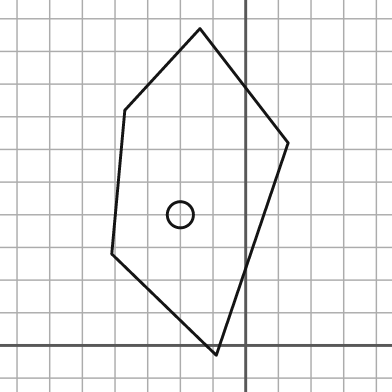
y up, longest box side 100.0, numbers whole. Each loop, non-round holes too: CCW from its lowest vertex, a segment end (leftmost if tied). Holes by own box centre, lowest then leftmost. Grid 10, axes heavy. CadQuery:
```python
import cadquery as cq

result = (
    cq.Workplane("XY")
    .moveTo(-9.0, -3.0)
    .lineTo(13.0, 62.0)
    .lineTo(-14.0, 97.0)
    .lineTo(-37.0, 72.0)
    .lineTo(-41.0, 28.0)
    .close()
    .moveTo(-20.0, 40.0)
    .circle(4.0)
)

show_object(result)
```